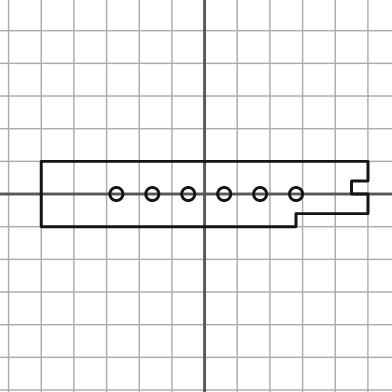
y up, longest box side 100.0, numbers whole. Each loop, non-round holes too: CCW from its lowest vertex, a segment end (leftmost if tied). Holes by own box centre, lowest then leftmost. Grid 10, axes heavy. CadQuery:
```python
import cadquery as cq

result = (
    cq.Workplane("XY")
    .moveTo(-50.0, -10.0)
    .lineTo(28.0, -10.0)
    .lineTo(28.0, -6.0)
    .lineTo(50.0, -6.0)
    .lineTo(50.0, 0.0)
    .lineTo(45.0, 0.0)
    .lineTo(45.0, 4.0)
    .lineTo(50.0, 4.0)
    .lineTo(50.0, 10.0)
    .lineTo(-50.0, 10.0)
    .close()
    .moveTo(-27.0, 0.0)
    .circle(2.0)
    .moveTo(-16.0, 0.0)
    .circle(2.0)
    .moveTo(-5.0, 0.0)
    .circle(2.0)
    .moveTo(6.0, 0.0)
    .circle(2.0)
    .moveTo(17.0, 0.0)
    .circle(2.0)
    .moveTo(28.0, 0.0)
    .circle(2.0)
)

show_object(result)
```